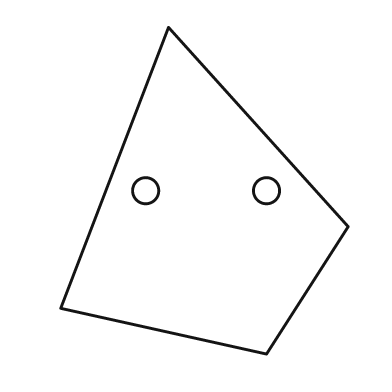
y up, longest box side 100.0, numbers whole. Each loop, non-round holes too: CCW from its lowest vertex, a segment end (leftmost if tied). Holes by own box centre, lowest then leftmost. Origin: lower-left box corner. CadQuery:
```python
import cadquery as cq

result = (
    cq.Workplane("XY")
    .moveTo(63.0, 0.0)
    .lineTo(88.0, 39.0)
    .lineTo(33.0, 100.0)
    .lineTo(0.0, 14.0)
    .close()
    .moveTo(26.0, 50.0)
    .circle(4.0)
    .moveTo(63.0, 50.0)
    .circle(4.0)
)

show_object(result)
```